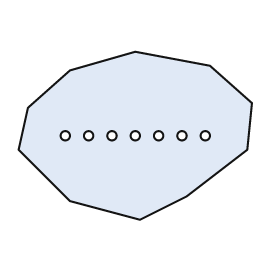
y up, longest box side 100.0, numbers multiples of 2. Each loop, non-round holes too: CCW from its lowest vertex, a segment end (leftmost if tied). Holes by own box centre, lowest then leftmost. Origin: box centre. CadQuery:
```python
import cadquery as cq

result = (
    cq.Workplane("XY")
    .moveTo(2.0, -36.0)
    .lineTo(22.0, -26.0)
    .lineTo(48.0, -6.0)
    .lineTo(50.0, 14.0)
    .lineTo(32.0, 30.0)
    .lineTo(0.0, 36.0)
    .lineTo(-28.0, 28.0)
    .lineTo(-46.0, 12.0)
    .lineTo(-50.0, -6.0)
    .lineTo(-28.0, -28.0)
    .close()
    .moveTo(-30.0, 0.0)
    .circle(2.0)
    .moveTo(-20.0, 0.0)
    .circle(2.0)
    .moveTo(-10.0, 0.0)
    .circle(2.0)
    .moveTo(0.0, 0.0)
    .circle(2.0)
    .moveTo(10.0, 0.0)
    .circle(2.0)
    .moveTo(20.0, 0.0)
    .circle(2.0)
    .moveTo(30.0, 0.0)
    .circle(2.0)
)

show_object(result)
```